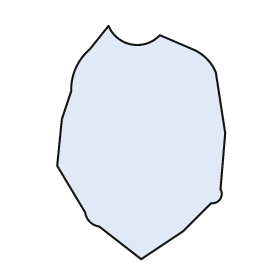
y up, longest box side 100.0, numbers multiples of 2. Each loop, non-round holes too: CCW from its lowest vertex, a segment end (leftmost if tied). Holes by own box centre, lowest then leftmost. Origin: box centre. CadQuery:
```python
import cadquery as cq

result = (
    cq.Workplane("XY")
    .moveTo(0.0, -50.0)
    .lineTo(18.0, -38.0)
    .lineTo(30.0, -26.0)
    .threePointArc((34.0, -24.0), (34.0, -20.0))
    .lineTo(36.0, 4.0)
    .lineTo(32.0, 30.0)
    .threePointArc((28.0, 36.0), (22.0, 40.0))
    .lineTo(8.0, 46.0)
    .threePointArc((-4.0, 42.0), (-14.0, 50.0))
    .lineTo(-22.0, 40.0)
    .threePointArc((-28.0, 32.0), (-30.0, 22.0))
    .lineTo(-34.0, 10.0)
    .lineTo(-36.0, -10.0)
    .lineTo(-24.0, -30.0)
    .threePointArc((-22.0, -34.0), (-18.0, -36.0))
    .close()
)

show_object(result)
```